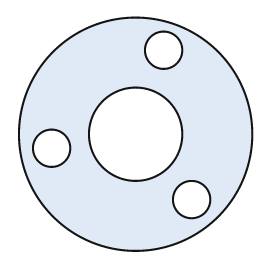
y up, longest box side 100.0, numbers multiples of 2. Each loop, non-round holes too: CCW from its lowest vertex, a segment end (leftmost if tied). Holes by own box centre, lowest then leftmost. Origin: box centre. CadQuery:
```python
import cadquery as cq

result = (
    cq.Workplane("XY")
    .moveTo(0.0, 0.0)
    .circle(50.0)
    .moveTo(24.0, -28.0)
    .circle(8.0)
    .moveTo(-36.0, -6.0)
    .circle(8.0)
    .moveTo(0.0, 0.0)
    .circle(20.0)
    .moveTo(12.0, 36.0)
    .circle(8.0)
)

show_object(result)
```